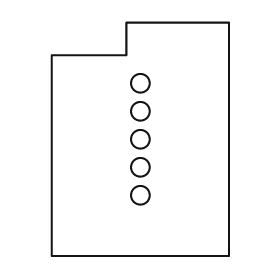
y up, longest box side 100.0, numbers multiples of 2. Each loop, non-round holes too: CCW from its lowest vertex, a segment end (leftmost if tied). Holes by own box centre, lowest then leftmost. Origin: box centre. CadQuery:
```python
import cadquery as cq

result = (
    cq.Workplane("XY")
    .moveTo(-38.0, -50.0)
    .lineTo(38.0, -50.0)
    .lineTo(38.0, 50.0)
    .lineTo(-6.0, 50.0)
    .lineTo(-6.0, 36.0)
    .lineTo(-38.0, 36.0)
    .close()
    .moveTo(0.0, -24.0)
    .circle(4.0)
    .moveTo(0.0, -12.0)
    .circle(4.0)
    .moveTo(0.0, 0.0)
    .circle(4.0)
    .moveTo(0.0, 12.0)
    .circle(4.0)
    .moveTo(0.0, 24.0)
    .circle(4.0)
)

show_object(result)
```